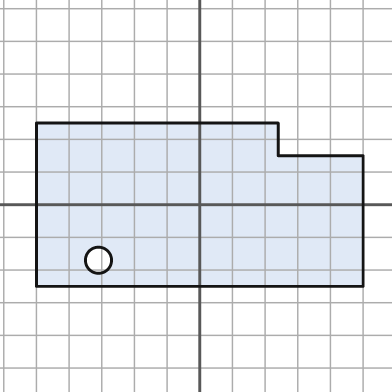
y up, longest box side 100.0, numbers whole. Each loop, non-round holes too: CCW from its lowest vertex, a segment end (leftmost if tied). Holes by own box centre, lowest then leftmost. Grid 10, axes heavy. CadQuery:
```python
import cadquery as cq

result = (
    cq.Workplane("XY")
    .moveTo(-50.0, -25.0)
    .lineTo(50.0, -25.0)
    .lineTo(50.0, 15.0)
    .lineTo(24.0, 15.0)
    .lineTo(24.0, 25.0)
    .lineTo(-50.0, 25.0)
    .close()
    .moveTo(-31.0, -17.0)
    .circle(4.0)
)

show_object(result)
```